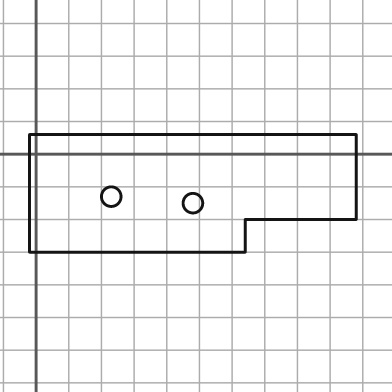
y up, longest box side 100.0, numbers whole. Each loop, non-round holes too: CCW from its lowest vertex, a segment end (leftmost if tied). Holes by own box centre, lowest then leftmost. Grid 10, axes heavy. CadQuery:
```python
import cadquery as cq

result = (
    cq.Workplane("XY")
    .moveTo(-2.0, -30.0)
    .lineTo(64.0, -30.0)
    .lineTo(64.0, -20.0)
    .lineTo(98.0, -20.0)
    .lineTo(98.0, 6.0)
    .lineTo(-2.0, 6.0)
    .close()
    .moveTo(48.0, -15.0)
    .circle(3.0)
    .moveTo(23.0, -13.0)
    .circle(3.0)
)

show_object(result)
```